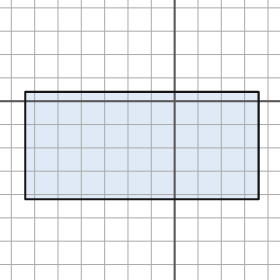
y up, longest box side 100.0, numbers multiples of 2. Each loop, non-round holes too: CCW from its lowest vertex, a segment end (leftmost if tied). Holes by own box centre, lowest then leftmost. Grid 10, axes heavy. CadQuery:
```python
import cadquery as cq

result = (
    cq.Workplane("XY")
    .moveTo(-64.0, -42.0)
    .lineTo(36.0, -42.0)
    .lineTo(36.0, 4.0)
    .lineTo(-64.0, 4.0)
    .close()
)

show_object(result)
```